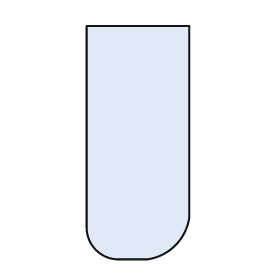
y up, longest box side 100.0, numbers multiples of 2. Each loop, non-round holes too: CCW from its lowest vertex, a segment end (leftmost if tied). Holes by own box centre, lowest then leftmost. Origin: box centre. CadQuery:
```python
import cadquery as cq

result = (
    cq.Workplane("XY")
    .moveTo(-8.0, -50.0)
    .lineTo(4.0, -50.0)
    .threePointArc((16.0, -44.0), (22.0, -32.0))
    .lineTo(22.0, 50.0)
    .lineTo(-22.0, 50.0)
    .lineTo(-22.0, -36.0)
    .threePointArc((-18.0, -46.0), (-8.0, -50.0))
    .close()
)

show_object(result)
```